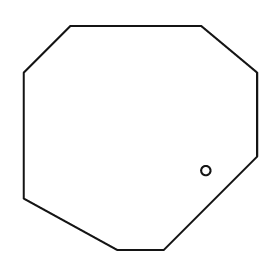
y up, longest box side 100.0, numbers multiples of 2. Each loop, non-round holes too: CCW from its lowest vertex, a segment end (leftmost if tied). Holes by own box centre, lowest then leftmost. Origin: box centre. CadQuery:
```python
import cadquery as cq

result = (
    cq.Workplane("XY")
    .moveTo(-10.0, -48.0)
    .lineTo(10.0, -48.0)
    .lineTo(50.0, -8.0)
    .lineTo(50.0, 28.0)
    .lineTo(26.0, 48.0)
    .lineTo(-30.0, 48.0)
    .lineTo(-50.0, 28.0)
    .lineTo(-50.0, -26.0)
    .close()
    .moveTo(28.0, -14.0)
    .circle(2.0)
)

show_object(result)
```